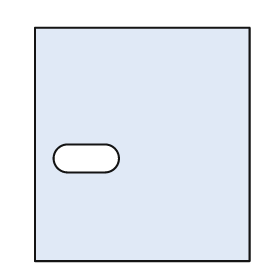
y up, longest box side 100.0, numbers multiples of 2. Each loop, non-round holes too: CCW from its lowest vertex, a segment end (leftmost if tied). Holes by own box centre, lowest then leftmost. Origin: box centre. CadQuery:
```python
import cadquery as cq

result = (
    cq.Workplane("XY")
    .moveTo(-46.0, -50.0)
    .lineTo(46.0, -50.0)
    .lineTo(46.0, 50.0)
    .lineTo(-46.0, 50.0)
    .close()
    .moveTo(-32.0, -12.0)
    .lineTo(-16.0, -12.0)
    .threePointArc((-10.0, -6.0), (-16.0, 0.0))
    .lineTo(-32.0, 0.0)
    .threePointArc((-38.0, -6.0), (-32.0, -12.0))
    .close()
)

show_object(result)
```